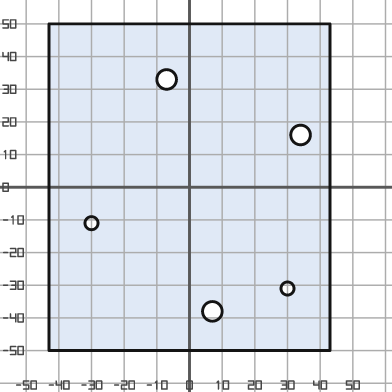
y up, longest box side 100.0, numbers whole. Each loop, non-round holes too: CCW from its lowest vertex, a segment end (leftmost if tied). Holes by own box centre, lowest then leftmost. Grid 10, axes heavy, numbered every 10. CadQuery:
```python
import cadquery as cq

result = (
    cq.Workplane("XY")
    .moveTo(-43.0, -50.0)
    .lineTo(43.0, -50.0)
    .lineTo(43.0, 50.0)
    .lineTo(-43.0, 50.0)
    .close()
    .moveTo(7.0, -38.0)
    .circle(3.0)
    .moveTo(30.0, -31.0)
    .circle(2.0)
    .moveTo(-30.0, -11.0)
    .circle(2.0)
    .moveTo(34.0, 16.0)
    .circle(3.0)
    .moveTo(-7.0, 33.0)
    .circle(3.0)
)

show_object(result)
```